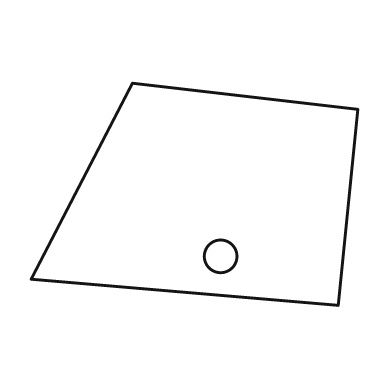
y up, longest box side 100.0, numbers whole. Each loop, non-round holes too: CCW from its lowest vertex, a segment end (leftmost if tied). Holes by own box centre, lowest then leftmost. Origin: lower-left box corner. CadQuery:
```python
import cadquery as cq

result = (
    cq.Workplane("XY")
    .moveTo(94.0, 0.0)
    .lineTo(100.0, 60.0)
    .lineTo(31.0, 68.0)
    .lineTo(0.0, 8.0)
    .close()
    .moveTo(58.0, 15.0)
    .circle(5.0)
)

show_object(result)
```